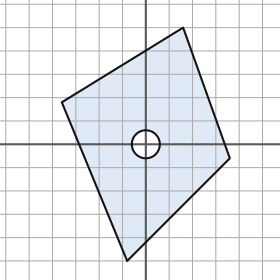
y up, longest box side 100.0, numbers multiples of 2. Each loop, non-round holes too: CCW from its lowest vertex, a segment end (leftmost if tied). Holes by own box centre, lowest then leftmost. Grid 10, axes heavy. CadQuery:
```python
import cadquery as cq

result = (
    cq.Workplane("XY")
    .moveTo(-8.0, -50.0)
    .lineTo(36.0, -6.0)
    .lineTo(16.0, 50.0)
    .lineTo(-36.0, 18.0)
    .close()
    .moveTo(0.0, 0.0)
    .circle(6.0)
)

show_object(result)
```